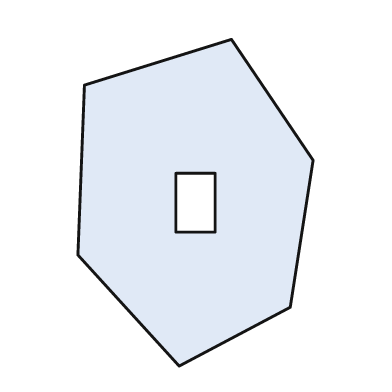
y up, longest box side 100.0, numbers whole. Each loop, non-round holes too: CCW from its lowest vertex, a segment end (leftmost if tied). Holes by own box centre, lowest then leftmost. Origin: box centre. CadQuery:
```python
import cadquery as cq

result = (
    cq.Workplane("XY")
    .moveTo(-5.0, -50.0)
    .lineTo(29.0, -32.0)
    .lineTo(36.0, 13.0)
    .lineTo(11.0, 50.0)
    .lineTo(-34.0, 36.0)
    .lineTo(-36.0, -16.0)
    .close()
    .moveTo(-6.0, -9.0)
    .lineTo(6.0, -9.0)
    .lineTo(6.0, 9.0)
    .lineTo(-6.0, 9.0)
    .close()
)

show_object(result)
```